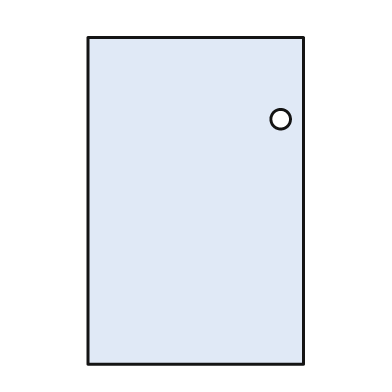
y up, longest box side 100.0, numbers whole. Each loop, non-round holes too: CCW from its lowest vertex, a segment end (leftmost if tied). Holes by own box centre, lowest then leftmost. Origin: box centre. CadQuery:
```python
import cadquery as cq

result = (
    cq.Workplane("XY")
    .moveTo(-33.0, -50.0)
    .lineTo(33.0, -50.0)
    .lineTo(33.0, 50.0)
    .lineTo(-33.0, 50.0)
    .close()
    .moveTo(26.0, 25.0)
    .circle(3.0)
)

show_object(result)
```